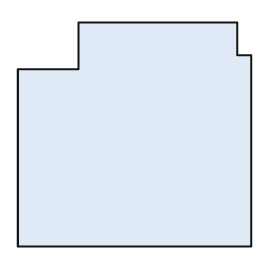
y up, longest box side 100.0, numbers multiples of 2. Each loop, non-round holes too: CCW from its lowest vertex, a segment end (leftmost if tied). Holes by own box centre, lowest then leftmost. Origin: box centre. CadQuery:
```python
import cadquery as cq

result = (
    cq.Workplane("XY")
    .moveTo(-50.0, -48.0)
    .lineTo(50.0, -48.0)
    .lineTo(50.0, 34.0)
    .lineTo(44.0, 34.0)
    .lineTo(44.0, 48.0)
    .lineTo(-24.0, 48.0)
    .lineTo(-24.0, 28.0)
    .lineTo(-50.0, 28.0)
    .close()
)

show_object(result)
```